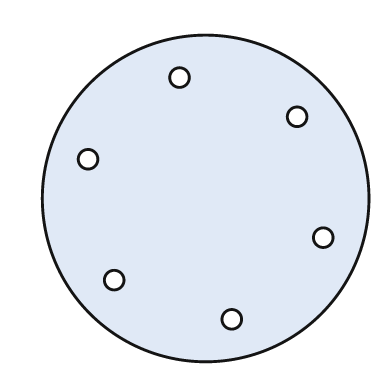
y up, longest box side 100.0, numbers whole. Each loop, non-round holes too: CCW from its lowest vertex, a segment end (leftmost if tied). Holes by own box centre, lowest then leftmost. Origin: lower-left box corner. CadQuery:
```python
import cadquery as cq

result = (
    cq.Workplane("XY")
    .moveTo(50.0, 50.0)
    .circle(50.0)
    .moveTo(58.0, 13.0)
    .circle(3.0)
    .moveTo(22.0, 25.0)
    .circle(3.0)
    .moveTo(86.0, 38.0)
    .circle(3.0)
    .moveTo(14.0, 62.0)
    .circle(3.0)
    .moveTo(78.0, 75.0)
    .circle(3.0)
    .moveTo(42.0, 87.0)
    .circle(3.0)
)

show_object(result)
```